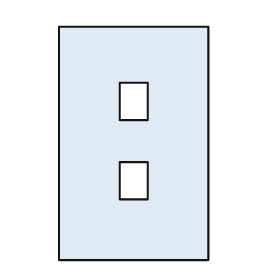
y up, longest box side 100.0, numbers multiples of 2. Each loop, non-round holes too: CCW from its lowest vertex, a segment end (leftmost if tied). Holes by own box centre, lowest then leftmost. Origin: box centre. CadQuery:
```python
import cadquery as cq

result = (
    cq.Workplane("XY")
    .moveTo(-32.0, -50.0)
    .lineTo(32.0, -50.0)
    .lineTo(32.0, 50.0)
    .lineTo(-32.0, 50.0)
    .close()
    .moveTo(-6.0, -24.0)
    .lineTo(6.0, -24.0)
    .lineTo(6.0, -8.0)
    .lineTo(-6.0, -8.0)
    .close()
    .moveTo(-6.0, 10.0)
    .lineTo(6.0, 10.0)
    .lineTo(6.0, 26.0)
    .lineTo(-6.0, 26.0)
    .close()
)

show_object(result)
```